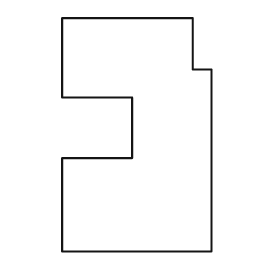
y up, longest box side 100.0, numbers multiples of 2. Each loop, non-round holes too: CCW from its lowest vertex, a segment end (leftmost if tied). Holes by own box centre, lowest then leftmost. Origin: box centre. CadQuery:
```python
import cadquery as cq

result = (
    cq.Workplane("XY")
    .moveTo(-32.0, -50.0)
    .lineTo(32.0, -50.0)
    .lineTo(32.0, 28.0)
    .lineTo(24.0, 28.0)
    .lineTo(24.0, 50.0)
    .lineTo(-32.0, 50.0)
    .lineTo(-32.0, 16.0)
    .lineTo(-2.0, 16.0)
    .lineTo(-2.0, -10.0)
    .lineTo(-32.0, -10.0)
    .close()
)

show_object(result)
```